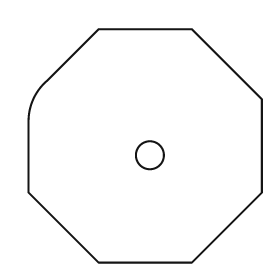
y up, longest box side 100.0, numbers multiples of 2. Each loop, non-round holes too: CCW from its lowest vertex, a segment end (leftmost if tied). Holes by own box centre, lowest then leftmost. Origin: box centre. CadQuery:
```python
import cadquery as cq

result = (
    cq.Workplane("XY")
    .moveTo(-20.0, -50.0)
    .lineTo(20.0, -50.0)
    .lineTo(50.0, -20.0)
    .lineTo(50.0, 20.0)
    .lineTo(20.0, 50.0)
    .lineTo(-20.0, 50.0)
    .lineTo(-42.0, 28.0)
    .threePointArc((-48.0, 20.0), (-50.0, 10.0))
    .lineTo(-50.0, -20.0)
    .close()
    .moveTo(2.0, -4.0)
    .circle(6.0)
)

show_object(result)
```